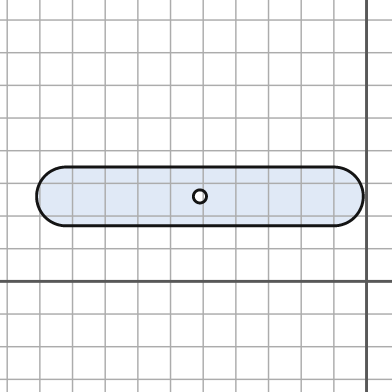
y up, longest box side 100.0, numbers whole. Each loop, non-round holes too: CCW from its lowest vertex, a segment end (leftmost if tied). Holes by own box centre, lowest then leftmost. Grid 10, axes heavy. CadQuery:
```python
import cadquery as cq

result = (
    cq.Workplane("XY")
    .moveTo(-92.0, 17.0)
    .lineTo(-10.0, 17.0)
    .threePointArc((-1.0, 26.0), (-10.0, 35.0))
    .lineTo(-92.0, 35.0)
    .threePointArc((-101.0, 26.0), (-92.0, 17.0))
    .close()
    .moveTo(-51.0, 26.0)
    .circle(2.0)
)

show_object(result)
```